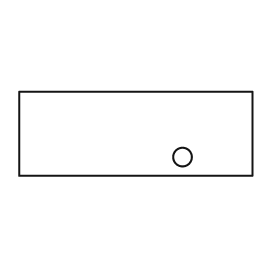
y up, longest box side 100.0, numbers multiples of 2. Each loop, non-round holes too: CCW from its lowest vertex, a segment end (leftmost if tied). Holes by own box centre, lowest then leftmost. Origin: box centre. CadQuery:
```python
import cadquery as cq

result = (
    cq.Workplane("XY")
    .moveTo(-50.0, -18.0)
    .lineTo(50.0, -18.0)
    .lineTo(50.0, 18.0)
    .lineTo(-50.0, 18.0)
    .close()
    .moveTo(20.0, -10.0)
    .circle(4.0)
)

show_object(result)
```